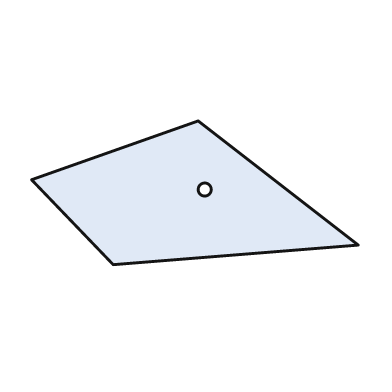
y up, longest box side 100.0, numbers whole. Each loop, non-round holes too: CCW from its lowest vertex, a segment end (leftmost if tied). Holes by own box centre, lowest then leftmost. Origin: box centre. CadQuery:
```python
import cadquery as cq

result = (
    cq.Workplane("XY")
    .moveTo(-25.0, -22.0)
    .lineTo(50.0, -16.0)
    .lineTo(1.0, 22.0)
    .lineTo(-50.0, 4.0)
    .close()
    .moveTo(3.0, 1.0)
    .circle(2.0)
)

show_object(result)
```